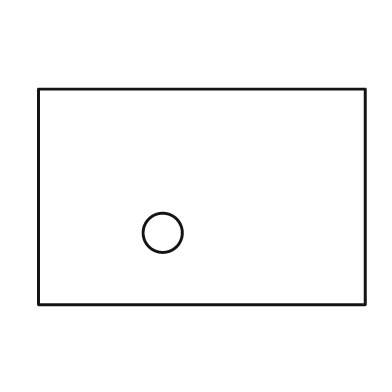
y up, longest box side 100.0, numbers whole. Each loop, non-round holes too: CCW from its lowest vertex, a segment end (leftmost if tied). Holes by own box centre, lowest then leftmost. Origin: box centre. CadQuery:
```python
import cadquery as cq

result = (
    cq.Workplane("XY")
    .moveTo(-50.0, -33.0)
    .lineTo(50.0, -33.0)
    .lineTo(50.0, 33.0)
    .lineTo(-50.0, 33.0)
    .close()
    .moveTo(-12.0, -11.0)
    .circle(6.0)
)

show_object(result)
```